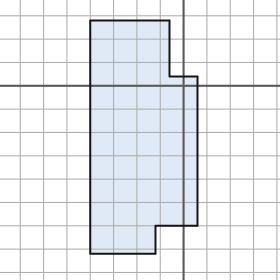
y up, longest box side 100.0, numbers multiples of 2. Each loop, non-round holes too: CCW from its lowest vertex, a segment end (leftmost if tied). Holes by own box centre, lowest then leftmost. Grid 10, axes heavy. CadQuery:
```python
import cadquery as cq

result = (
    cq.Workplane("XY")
    .moveTo(-40.0, -72.0)
    .lineTo(-12.0, -72.0)
    .lineTo(-12.0, -60.0)
    .lineTo(6.0, -60.0)
    .lineTo(6.0, 4.0)
    .lineTo(-6.0, 4.0)
    .lineTo(-6.0, 28.0)
    .lineTo(-40.0, 28.0)
    .close()
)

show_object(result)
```